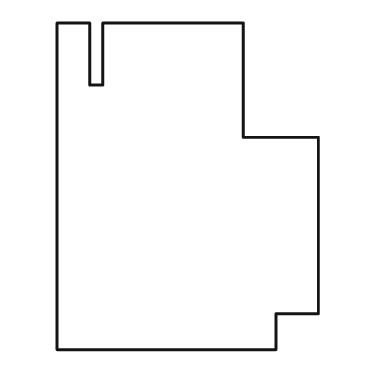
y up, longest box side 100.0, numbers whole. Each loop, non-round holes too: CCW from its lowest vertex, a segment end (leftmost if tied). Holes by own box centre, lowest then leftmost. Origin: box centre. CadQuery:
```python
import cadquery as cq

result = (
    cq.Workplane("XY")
    .moveTo(-40.0, -50.0)
    .lineTo(27.0, -50.0)
    .lineTo(27.0, -39.0)
    .lineTo(40.0, -39.0)
    .lineTo(40.0, 15.0)
    .lineTo(17.0, 15.0)
    .lineTo(17.0, 50.0)
    .lineTo(-26.0, 50.0)
    .lineTo(-26.0, 31.0)
    .lineTo(-30.0, 31.0)
    .lineTo(-30.0, 50.0)
    .lineTo(-40.0, 50.0)
    .close()
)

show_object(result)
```